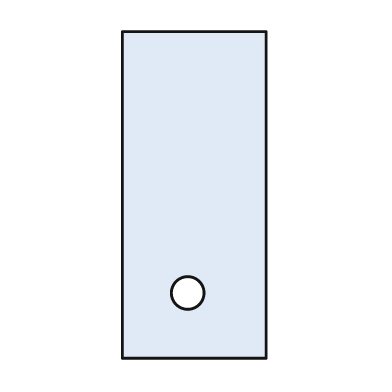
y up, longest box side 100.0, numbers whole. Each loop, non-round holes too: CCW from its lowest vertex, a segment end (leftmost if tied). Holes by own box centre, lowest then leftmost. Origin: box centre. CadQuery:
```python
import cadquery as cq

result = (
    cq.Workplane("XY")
    .moveTo(-22.0, -50.0)
    .lineTo(22.0, -50.0)
    .lineTo(22.0, 50.0)
    .lineTo(-22.0, 50.0)
    .close()
    .moveTo(-2.0, -30.0)
    .circle(5.0)
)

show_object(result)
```